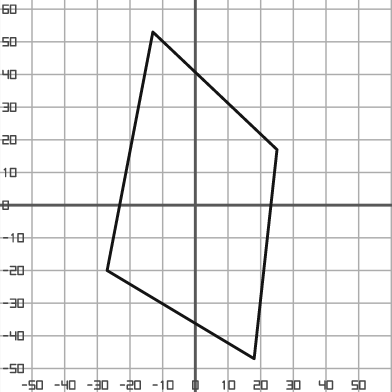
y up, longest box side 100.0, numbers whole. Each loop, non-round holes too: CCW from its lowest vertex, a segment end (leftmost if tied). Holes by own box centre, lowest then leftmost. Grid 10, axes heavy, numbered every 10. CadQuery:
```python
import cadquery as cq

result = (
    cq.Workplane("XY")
    .moveTo(18.0, -47.0)
    .lineTo(25.0, 17.0)
    .lineTo(-13.0, 53.0)
    .lineTo(-27.0, -20.0)
    .close()
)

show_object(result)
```